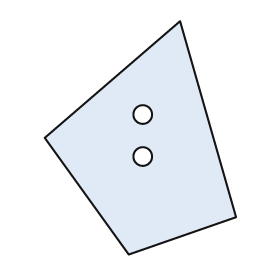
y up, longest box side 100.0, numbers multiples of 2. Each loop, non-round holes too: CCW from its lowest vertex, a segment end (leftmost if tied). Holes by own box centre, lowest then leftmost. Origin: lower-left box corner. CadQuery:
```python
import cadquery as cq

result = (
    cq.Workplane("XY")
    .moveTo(36.0, 0.0)
    .lineTo(82.0, 16.0)
    .lineTo(58.0, 100.0)
    .lineTo(0.0, 50.0)
    .close()
    .moveTo(42.0, 42.0)
    .circle(4.0)
    .moveTo(42.0, 60.0)
    .circle(4.0)
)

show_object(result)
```